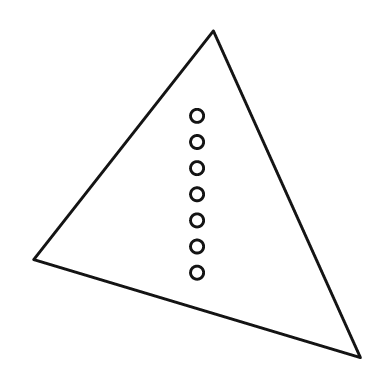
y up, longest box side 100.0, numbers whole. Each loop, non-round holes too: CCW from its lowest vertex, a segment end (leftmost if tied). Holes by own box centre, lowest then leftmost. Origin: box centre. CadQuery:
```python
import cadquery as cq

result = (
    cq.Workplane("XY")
    .moveTo(50.0, -50.0)
    .lineTo(5.0, 50.0)
    .lineTo(-50.0, -20.0)
    .close()
    .moveTo(0.0, -24.0)
    .circle(2.0)
    .moveTo(0.0, -16.0)
    .circle(2.0)
    .moveTo(0.0, -8.0)
    .circle(2.0)
    .moveTo(0.0, 0.0)
    .circle(2.0)
    .moveTo(0.0, 8.0)
    .circle(2.0)
    .moveTo(0.0, 16.0)
    .circle(2.0)
    .moveTo(0.0, 24.0)
    .circle(2.0)
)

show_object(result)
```